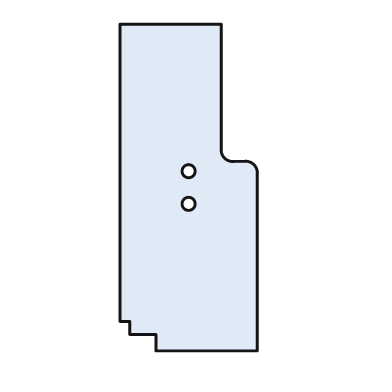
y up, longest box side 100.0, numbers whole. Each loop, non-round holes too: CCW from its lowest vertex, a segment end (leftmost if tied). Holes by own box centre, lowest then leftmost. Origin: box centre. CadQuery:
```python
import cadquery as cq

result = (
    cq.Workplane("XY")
    .moveTo(-10.0, -50.0)
    .lineTo(21.0, -50.0)
    .lineTo(21.0, 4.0)
    .threePointArc((20.0, 7.0), (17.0, 8.0))
    .lineTo(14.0, 8.0)
    .threePointArc((11.0, 9.0), (10.0, 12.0))
    .lineTo(10.0, 50.0)
    .lineTo(-21.0, 50.0)
    .lineTo(-21.0, -41.0)
    .lineTo(-18.0, -41.0)
    .lineTo(-18.0, -45.0)
    .lineTo(-10.0, -45.0)
    .close()
    .moveTo(0.0, -5.0)
    .circle(2.0)
    .moveTo(0.0, 5.0)
    .circle(2.0)
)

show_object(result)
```